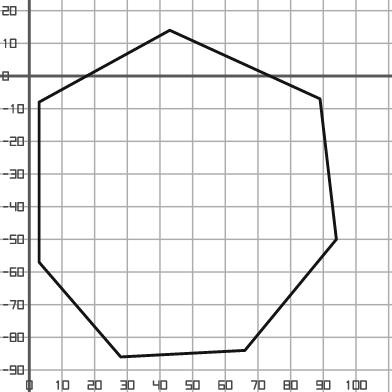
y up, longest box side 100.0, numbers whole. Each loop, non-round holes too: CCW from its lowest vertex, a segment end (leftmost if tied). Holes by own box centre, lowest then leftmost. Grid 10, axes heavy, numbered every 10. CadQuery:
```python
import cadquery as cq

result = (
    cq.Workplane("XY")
    .moveTo(28.0, -86.0)
    .lineTo(66.0, -84.0)
    .lineTo(94.0, -50.0)
    .lineTo(89.0, -7.0)
    .lineTo(43.0, 14.0)
    .lineTo(3.0, -8.0)
    .lineTo(3.0, -57.0)
    .close()
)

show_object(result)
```